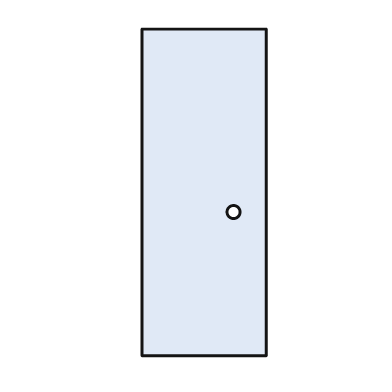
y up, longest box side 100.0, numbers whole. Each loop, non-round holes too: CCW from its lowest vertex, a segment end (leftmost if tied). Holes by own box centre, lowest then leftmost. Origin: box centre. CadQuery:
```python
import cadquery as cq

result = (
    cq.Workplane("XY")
    .moveTo(-19.0, -50.0)
    .lineTo(19.0, -50.0)
    .lineTo(19.0, 50.0)
    .lineTo(-19.0, 50.0)
    .close()
    .moveTo(9.0, -6.0)
    .circle(2.0)
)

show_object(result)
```